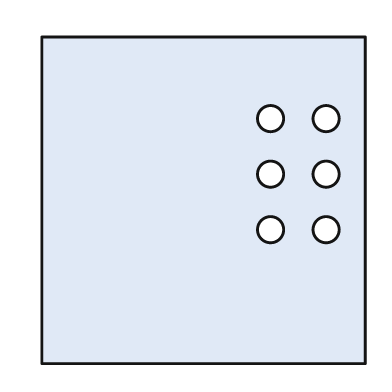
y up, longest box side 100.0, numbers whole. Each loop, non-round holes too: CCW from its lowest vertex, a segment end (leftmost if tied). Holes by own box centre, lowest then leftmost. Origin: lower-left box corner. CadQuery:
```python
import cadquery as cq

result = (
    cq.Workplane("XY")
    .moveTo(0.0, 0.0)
    .lineTo(99.0, 0.0)
    .lineTo(99.0, 100.0)
    .lineTo(0.0, 100.0)
    .close()
    .moveTo(70.0, 41.0)
    .circle(4.0)
    .moveTo(87.0, 41.0)
    .circle(4.0)
    .moveTo(70.0, 58.0)
    .circle(4.0)
    .moveTo(87.0, 58.0)
    .circle(4.0)
    .moveTo(70.0, 75.0)
    .circle(4.0)
    .moveTo(87.0, 75.0)
    .circle(4.0)
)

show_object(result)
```